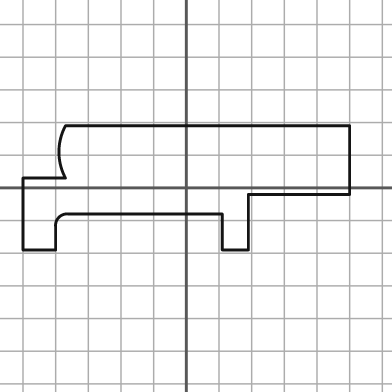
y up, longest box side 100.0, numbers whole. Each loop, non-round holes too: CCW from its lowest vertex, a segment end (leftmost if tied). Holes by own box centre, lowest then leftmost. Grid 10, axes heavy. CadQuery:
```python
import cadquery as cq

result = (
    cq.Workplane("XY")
    .moveTo(-50.0, -19.0)
    .lineTo(-40.0, -19.0)
    .lineTo(-40.0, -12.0)
    .threePointArc((-39.0, -9.0), (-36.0, -8.0))
    .lineTo(11.0, -8.0)
    .lineTo(11.0, -19.0)
    .lineTo(19.0, -19.0)
    .lineTo(19.0, -2.0)
    .lineTo(50.0, -2.0)
    .lineTo(50.0, 19.0)
    .lineTo(-37.0, 19.0)
    .threePointArc((-39.0, 11.0), (-37.0, 3.0))
    .lineTo(-50.0, 3.0)
    .close()
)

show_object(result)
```